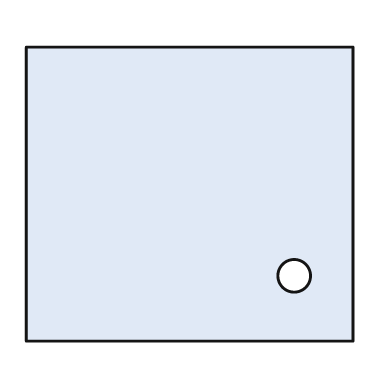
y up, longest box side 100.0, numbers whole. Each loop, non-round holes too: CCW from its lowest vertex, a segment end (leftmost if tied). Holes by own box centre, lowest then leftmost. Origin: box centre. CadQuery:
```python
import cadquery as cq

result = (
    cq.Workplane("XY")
    .moveTo(-50.0, -45.0)
    .lineTo(50.0, -45.0)
    .lineTo(50.0, 45.0)
    .lineTo(-50.0, 45.0)
    .close()
    .moveTo(32.0, -25.0)
    .circle(5.0)
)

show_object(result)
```